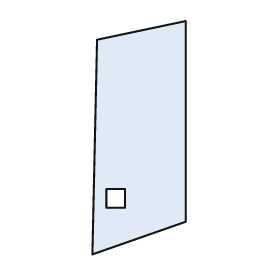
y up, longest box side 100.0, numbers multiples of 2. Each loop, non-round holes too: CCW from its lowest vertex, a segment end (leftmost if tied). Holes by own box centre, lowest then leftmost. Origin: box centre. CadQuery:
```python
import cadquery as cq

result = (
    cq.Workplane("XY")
    .moveTo(-20.0, -50.0)
    .lineTo(20.0, -36.0)
    .lineTo(20.0, 50.0)
    .lineTo(-18.0, 42.0)
    .close()
    .moveTo(-14.0, -30.0)
    .lineTo(-6.0, -30.0)
    .lineTo(-6.0, -22.0)
    .lineTo(-14.0, -22.0)
    .close()
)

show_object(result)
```